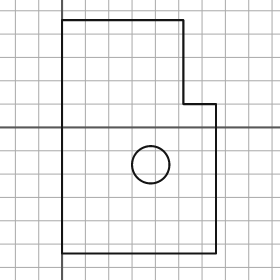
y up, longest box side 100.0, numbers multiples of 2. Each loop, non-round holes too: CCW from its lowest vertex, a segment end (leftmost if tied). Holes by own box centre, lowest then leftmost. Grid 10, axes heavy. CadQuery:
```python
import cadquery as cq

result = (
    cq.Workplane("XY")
    .moveTo(0.0, -54.0)
    .lineTo(66.0, -54.0)
    .lineTo(66.0, 10.0)
    .lineTo(52.0, 10.0)
    .lineTo(52.0, 46.0)
    .lineTo(0.0, 46.0)
    .close()
    .moveTo(38.0, -16.0)
    .circle(8.0)
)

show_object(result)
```